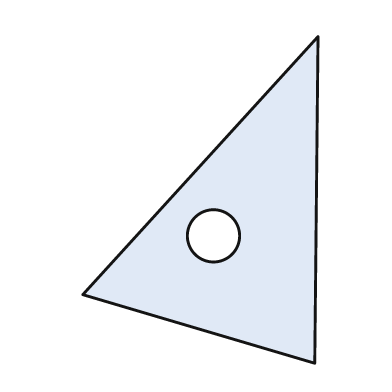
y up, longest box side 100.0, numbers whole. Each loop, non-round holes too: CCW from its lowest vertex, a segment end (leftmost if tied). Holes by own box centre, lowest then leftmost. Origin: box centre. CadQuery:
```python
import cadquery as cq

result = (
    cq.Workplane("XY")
    .moveTo(35.0, -50.0)
    .lineTo(36.0, 50.0)
    .lineTo(-36.0, -29.0)
    .close()
    .moveTo(4.0, -11.0)
    .circle(8.0)
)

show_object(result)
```